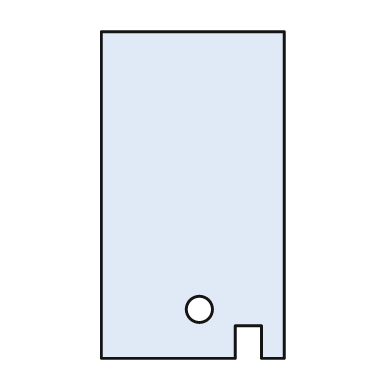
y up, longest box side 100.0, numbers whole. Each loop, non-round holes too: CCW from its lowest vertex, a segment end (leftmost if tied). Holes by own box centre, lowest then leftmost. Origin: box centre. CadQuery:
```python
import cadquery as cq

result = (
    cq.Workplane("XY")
    .moveTo(-28.0, -50.0)
    .lineTo(13.0, -50.0)
    .lineTo(13.0, -40.0)
    .lineTo(21.0, -40.0)
    .lineTo(21.0, -50.0)
    .lineTo(28.0, -50.0)
    .lineTo(28.0, 50.0)
    .lineTo(-28.0, 50.0)
    .close()
    .moveTo(2.0, -35.0)
    .circle(4.0)
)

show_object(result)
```